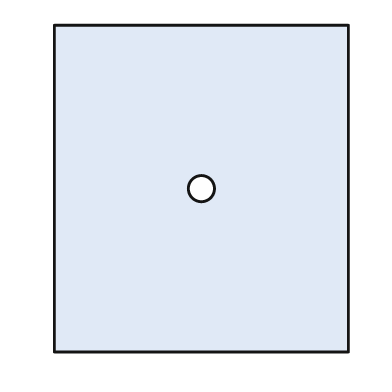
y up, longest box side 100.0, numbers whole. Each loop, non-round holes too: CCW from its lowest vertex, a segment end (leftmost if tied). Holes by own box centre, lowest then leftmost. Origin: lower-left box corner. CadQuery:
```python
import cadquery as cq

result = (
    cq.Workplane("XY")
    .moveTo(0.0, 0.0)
    .lineTo(90.0, 0.0)
    .lineTo(90.0, 100.0)
    .lineTo(0.0, 100.0)
    .close()
    .moveTo(45.0, 50.0)
    .circle(4.0)
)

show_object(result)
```